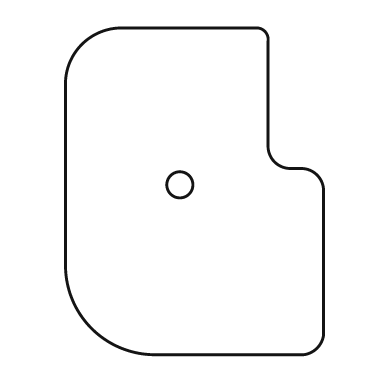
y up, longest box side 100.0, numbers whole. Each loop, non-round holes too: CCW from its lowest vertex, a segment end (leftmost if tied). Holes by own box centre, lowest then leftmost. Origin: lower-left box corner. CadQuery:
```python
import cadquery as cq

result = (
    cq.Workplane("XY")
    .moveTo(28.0, 0.0)
    .lineTo(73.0, 0.0)
    .threePointArc((77.0, 2.0), (79.0, 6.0))
    .lineTo(79.0, 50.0)
    .threePointArc((77.0, 55.0), (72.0, 57.0))
    .lineTo(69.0, 57.0)
    .threePointArc((64.0, 59.0), (62.0, 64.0))
    .lineTo(62.0, 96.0)
    .threePointArc((61.0, 99.0), (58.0, 100.0))
    .lineTo(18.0, 100.0)
    .threePointArc((5.0, 95.0), (0.0, 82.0))
    .lineTo(0.0, 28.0)
    .threePointArc((8.0, 8.0), (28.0, 0.0))
    .close()
    .moveTo(35.0, 52.0)
    .circle(4.0)
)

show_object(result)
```